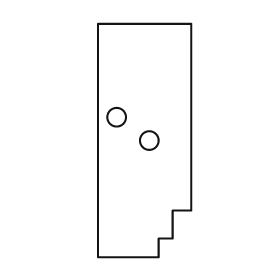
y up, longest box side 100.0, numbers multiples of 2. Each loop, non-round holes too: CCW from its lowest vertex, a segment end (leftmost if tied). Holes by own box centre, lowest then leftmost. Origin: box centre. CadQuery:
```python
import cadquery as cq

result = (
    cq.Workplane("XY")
    .moveTo(-20.0, -50.0)
    .lineTo(6.0, -50.0)
    .lineTo(6.0, -42.0)
    .lineTo(12.0, -42.0)
    .lineTo(12.0, -30.0)
    .lineTo(20.0, -30.0)
    .lineTo(20.0, 50.0)
    .lineTo(-20.0, 50.0)
    .close()
    .moveTo(2.0, 0.0)
    .circle(4.0)
    .moveTo(-12.0, 10.0)
    .circle(4.0)
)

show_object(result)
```